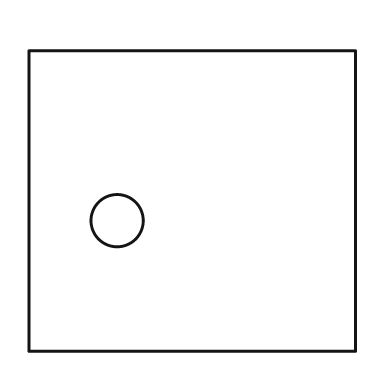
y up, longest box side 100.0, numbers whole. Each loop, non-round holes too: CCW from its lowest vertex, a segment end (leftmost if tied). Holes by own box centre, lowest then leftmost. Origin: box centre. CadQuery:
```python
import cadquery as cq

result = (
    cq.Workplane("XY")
    .moveTo(-50.0, -46.0)
    .lineTo(50.0, -46.0)
    .lineTo(50.0, 46.0)
    .lineTo(-50.0, 46.0)
    .close()
    .moveTo(-23.0, -6.0)
    .circle(8.0)
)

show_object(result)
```